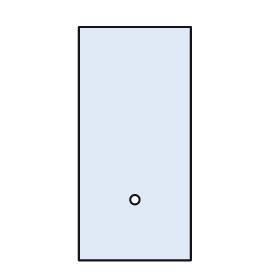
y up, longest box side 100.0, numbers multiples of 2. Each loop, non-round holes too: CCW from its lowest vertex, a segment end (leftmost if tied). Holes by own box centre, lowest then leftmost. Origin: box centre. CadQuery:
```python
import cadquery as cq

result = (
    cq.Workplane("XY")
    .moveTo(-24.0, -50.0)
    .lineTo(24.0, -50.0)
    .lineTo(24.0, 50.0)
    .lineTo(-24.0, 50.0)
    .close()
    .moveTo(0.0, -24.0)
    .circle(2.0)
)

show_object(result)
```